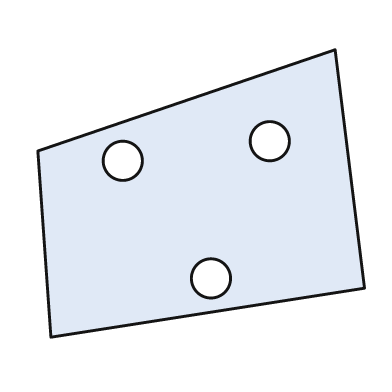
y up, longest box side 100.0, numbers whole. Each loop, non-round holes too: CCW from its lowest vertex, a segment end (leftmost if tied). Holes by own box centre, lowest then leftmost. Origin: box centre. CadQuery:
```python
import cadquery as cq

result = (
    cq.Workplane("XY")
    .moveTo(-46.0, -44.0)
    .lineTo(50.0, -29.0)
    .lineTo(41.0, 44.0)
    .lineTo(-50.0, 13.0)
    .close()
    .moveTo(3.0, -26.0)
    .circle(6.0)
    .moveTo(-24.0, 10.0)
    .circle(6.0)
    .moveTo(21.0, 16.0)
    .circle(6.0)
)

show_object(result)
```